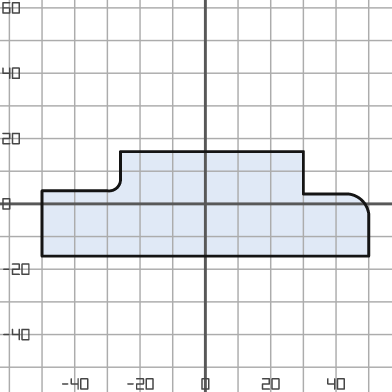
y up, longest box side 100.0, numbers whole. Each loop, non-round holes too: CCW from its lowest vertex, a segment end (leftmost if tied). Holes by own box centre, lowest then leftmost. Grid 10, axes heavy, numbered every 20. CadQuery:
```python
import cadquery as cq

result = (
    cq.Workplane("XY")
    .moveTo(-50.0, -16.0)
    .lineTo(50.0, -16.0)
    .lineTo(50.0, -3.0)
    .threePointArc((48.0, 1.0), (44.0, 3.0))
    .lineTo(30.0, 3.0)
    .lineTo(30.0, 16.0)
    .lineTo(-26.0, 16.0)
    .lineTo(-26.0, 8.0)
    .threePointArc((-27.0, 5.0), (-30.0, 4.0))
    .lineTo(-50.0, 4.0)
    .close()
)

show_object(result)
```